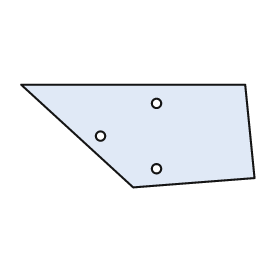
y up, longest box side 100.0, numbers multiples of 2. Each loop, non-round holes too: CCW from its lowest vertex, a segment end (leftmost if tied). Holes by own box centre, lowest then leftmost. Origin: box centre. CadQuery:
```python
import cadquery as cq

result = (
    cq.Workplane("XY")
    .moveTo(-2.0, -22.0)
    .lineTo(50.0, -18.0)
    .lineTo(46.0, 22.0)
    .lineTo(-50.0, 22.0)
    .close()
    .moveTo(8.0, -14.0)
    .circle(2.0)
    .moveTo(-16.0, 0.0)
    .circle(2.0)
    .moveTo(8.0, 14.0)
    .circle(2.0)
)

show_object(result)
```